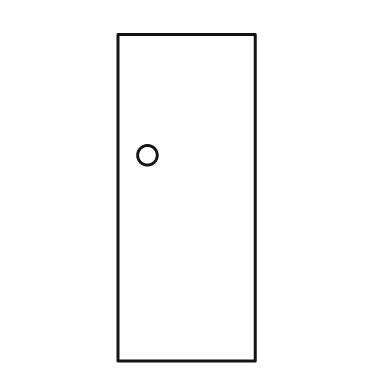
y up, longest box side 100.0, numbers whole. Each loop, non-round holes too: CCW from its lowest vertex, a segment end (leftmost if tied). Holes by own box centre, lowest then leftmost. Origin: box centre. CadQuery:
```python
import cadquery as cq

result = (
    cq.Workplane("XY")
    .moveTo(-21.0, -50.0)
    .lineTo(21.0, -50.0)
    .lineTo(21.0, 50.0)
    .lineTo(-21.0, 50.0)
    .close()
    .moveTo(-12.0, 13.0)
    .circle(3.0)
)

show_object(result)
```